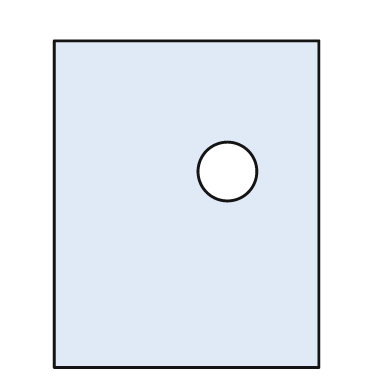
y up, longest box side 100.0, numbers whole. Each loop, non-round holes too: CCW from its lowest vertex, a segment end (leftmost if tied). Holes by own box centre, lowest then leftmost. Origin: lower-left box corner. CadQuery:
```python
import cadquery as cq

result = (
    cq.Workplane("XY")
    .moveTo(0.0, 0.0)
    .lineTo(81.0, 0.0)
    .lineTo(81.0, 100.0)
    .lineTo(0.0, 100.0)
    .close()
    .moveTo(53.0, 60.0)
    .circle(9.0)
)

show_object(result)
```